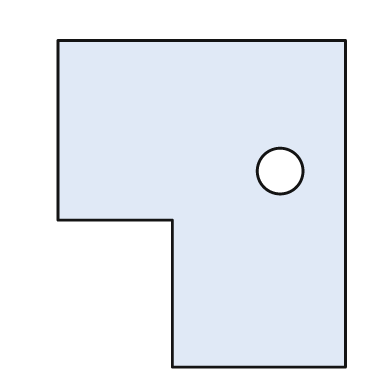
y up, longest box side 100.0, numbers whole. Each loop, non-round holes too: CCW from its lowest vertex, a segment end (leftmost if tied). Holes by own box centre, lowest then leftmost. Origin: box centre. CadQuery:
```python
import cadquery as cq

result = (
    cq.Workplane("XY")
    .moveTo(-9.0, -50.0)
    .lineTo(44.0, -50.0)
    .lineTo(44.0, 50.0)
    .lineTo(-44.0, 50.0)
    .lineTo(-44.0, -5.0)
    .lineTo(-9.0, -5.0)
    .close()
    .moveTo(24.0, 10.0)
    .circle(7.0)
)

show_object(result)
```